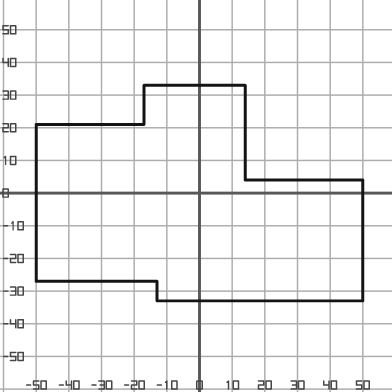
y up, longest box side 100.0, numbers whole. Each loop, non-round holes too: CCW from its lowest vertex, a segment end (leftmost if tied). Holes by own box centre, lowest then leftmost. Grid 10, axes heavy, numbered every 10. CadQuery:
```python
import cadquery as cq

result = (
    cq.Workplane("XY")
    .moveTo(-13.0, -33.0)
    .lineTo(50.0, -33.0)
    .lineTo(50.0, 4.0)
    .lineTo(14.0, 4.0)
    .lineTo(14.0, 33.0)
    .lineTo(-17.0, 33.0)
    .lineTo(-17.0, 21.0)
    .lineTo(-50.0, 21.0)
    .lineTo(-50.0, -27.0)
    .lineTo(-13.0, -27.0)
    .close()
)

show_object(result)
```